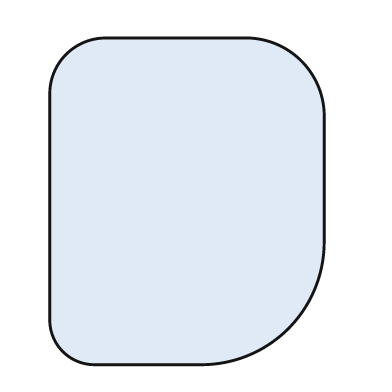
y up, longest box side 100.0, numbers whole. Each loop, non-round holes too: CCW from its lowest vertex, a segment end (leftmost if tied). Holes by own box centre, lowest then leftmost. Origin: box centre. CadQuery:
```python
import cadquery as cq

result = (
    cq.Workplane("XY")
    .moveTo(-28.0, -50.0)
    .lineTo(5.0, -50.0)
    .threePointArc((31.0, -39.0), (42.0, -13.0))
    .lineTo(42.0, 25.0)
    .threePointArc((35.0, 43.0), (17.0, 50.0))
    .lineTo(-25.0, 50.0)
    .threePointArc((-37.0, 45.0), (-42.0, 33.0))
    .lineTo(-42.0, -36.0)
    .threePointArc((-38.0, -46.0), (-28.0, -50.0))
    .close()
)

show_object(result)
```